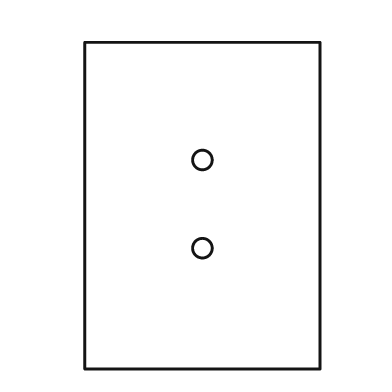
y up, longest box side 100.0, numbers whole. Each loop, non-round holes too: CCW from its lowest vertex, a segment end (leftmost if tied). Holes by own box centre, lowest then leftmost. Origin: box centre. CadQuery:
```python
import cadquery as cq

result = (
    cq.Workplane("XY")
    .moveTo(-36.0, -50.0)
    .lineTo(36.0, -50.0)
    .lineTo(36.0, 50.0)
    .lineTo(-36.0, 50.0)
    .close()
    .moveTo(0.0, -13.0)
    .circle(3.0)
    .moveTo(0.0, 14.0)
    .circle(3.0)
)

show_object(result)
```